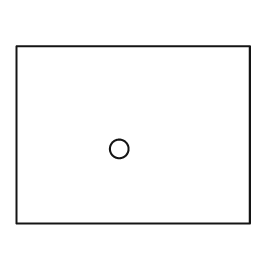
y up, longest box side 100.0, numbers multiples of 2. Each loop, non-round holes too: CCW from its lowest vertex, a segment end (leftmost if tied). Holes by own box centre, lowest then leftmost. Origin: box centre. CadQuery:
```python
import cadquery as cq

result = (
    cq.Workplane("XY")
    .moveTo(-50.0, -38.0)
    .lineTo(50.0, -38.0)
    .lineTo(50.0, 38.0)
    .lineTo(-50.0, 38.0)
    .close()
    .moveTo(-6.0, -6.0)
    .circle(4.0)
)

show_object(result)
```